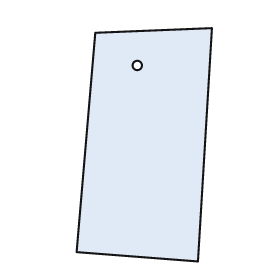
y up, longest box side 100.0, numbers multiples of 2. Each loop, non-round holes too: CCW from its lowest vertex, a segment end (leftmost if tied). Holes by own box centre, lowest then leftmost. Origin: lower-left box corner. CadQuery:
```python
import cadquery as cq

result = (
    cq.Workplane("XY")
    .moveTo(52.0, 0.0)
    .lineTo(58.0, 100.0)
    .lineTo(8.0, 98.0)
    .lineTo(0.0, 4.0)
    .close()
    .moveTo(26.0, 84.0)
    .circle(2.0)
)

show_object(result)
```